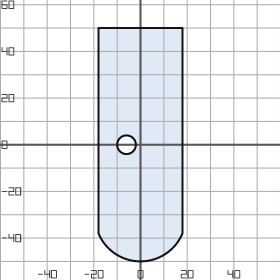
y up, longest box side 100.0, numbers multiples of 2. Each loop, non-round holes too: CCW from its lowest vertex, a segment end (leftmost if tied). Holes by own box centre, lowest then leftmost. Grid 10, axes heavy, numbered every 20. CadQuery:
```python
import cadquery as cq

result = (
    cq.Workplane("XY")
    .moveTo(-18.0, -38.0)
    .threePointArc((0.0, -50.0), (18.0, -38.0))
    .lineTo(18.0, 50.0)
    .lineTo(-18.0, 50.0)
    .close()
    .moveTo(-6.0, 0.0)
    .circle(4.0)
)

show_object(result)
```